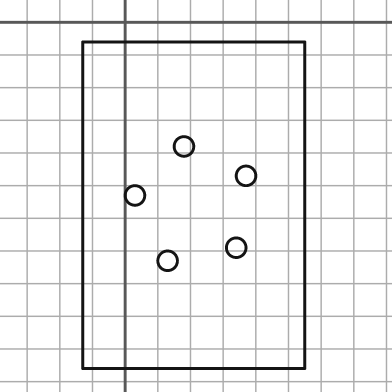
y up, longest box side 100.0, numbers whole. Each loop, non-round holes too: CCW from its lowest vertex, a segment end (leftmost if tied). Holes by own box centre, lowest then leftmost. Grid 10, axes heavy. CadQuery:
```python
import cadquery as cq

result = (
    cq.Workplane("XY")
    .moveTo(-13.0, -106.0)
    .lineTo(55.0, -106.0)
    .lineTo(55.0, -6.0)
    .lineTo(-13.0, -6.0)
    .close()
    .moveTo(13.0, -73.0)
    .circle(3.0)
    .moveTo(34.0, -69.0)
    .circle(3.0)
    .moveTo(3.0, -53.0)
    .circle(3.0)
    .moveTo(37.0, -47.0)
    .circle(3.0)
    .moveTo(18.0, -38.0)
    .circle(3.0)
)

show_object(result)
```